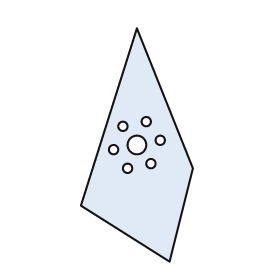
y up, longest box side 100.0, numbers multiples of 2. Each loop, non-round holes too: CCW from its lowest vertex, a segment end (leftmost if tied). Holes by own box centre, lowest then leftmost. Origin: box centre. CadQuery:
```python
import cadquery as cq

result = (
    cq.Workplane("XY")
    .moveTo(14.0, -50.0)
    .lineTo(24.0, -10.0)
    .lineTo(0.0, 50.0)
    .lineTo(-24.0, -26.0)
    .close()
    .moveTo(-4.0, -10.0)
    .circle(2.0)
    .moveTo(6.0, -8.0)
    .circle(2.0)
    .moveTo(-10.0, -2.0)
    .circle(2.0)
    .moveTo(0.0, 0.0)
    .circle(4.0)
    .moveTo(10.0, 2.0)
    .circle(2.0)
    .moveTo(-6.0, 8.0)
    .circle(2.0)
    .moveTo(4.0, 10.0)
    .circle(2.0)
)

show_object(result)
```